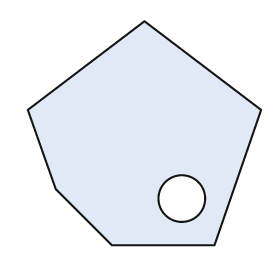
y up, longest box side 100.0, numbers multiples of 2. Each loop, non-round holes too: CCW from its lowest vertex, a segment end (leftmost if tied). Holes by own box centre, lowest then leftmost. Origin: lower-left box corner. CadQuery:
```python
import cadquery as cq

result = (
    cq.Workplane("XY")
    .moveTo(36.0, 0.0)
    .lineTo(80.0, 0.0)
    .lineTo(100.0, 58.0)
    .lineTo(50.0, 96.0)
    .lineTo(0.0, 58.0)
    .lineTo(12.0, 24.0)
    .close()
    .moveTo(66.0, 20.0)
    .circle(10.0)
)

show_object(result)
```